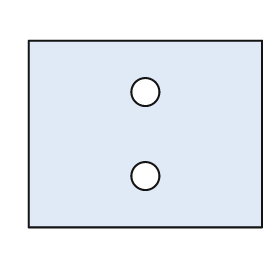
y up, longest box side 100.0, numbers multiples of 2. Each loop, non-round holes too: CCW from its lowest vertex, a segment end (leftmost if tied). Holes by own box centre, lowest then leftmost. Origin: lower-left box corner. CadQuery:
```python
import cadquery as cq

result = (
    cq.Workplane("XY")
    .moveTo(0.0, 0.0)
    .lineTo(100.0, 0.0)
    .lineTo(100.0, 80.0)
    .lineTo(0.0, 80.0)
    .close()
    .moveTo(50.0, 22.0)
    .circle(6.0)
    .moveTo(50.0, 58.0)
    .circle(6.0)
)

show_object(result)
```